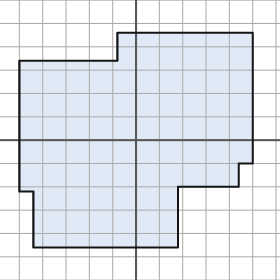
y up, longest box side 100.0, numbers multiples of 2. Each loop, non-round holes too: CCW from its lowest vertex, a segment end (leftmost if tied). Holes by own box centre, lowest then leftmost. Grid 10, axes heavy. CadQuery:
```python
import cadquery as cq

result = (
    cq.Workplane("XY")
    .moveTo(-44.0, -46.0)
    .lineTo(18.0, -46.0)
    .lineTo(18.0, -20.0)
    .lineTo(44.0, -20.0)
    .lineTo(44.0, -10.0)
    .lineTo(50.0, -10.0)
    .lineTo(50.0, 46.0)
    .lineTo(-8.0, 46.0)
    .lineTo(-8.0, 34.0)
    .lineTo(-50.0, 34.0)
    .lineTo(-50.0, -22.0)
    .lineTo(-44.0, -22.0)
    .close()
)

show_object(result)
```